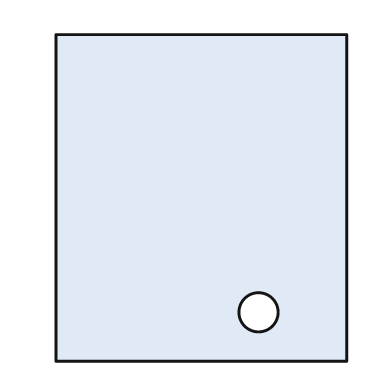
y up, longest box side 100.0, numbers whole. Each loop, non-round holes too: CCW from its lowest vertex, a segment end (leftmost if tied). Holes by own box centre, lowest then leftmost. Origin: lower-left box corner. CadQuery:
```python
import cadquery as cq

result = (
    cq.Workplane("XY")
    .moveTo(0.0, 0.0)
    .lineTo(89.0, 0.0)
    .lineTo(89.0, 100.0)
    .lineTo(0.0, 100.0)
    .close()
    .moveTo(62.0, 15.0)
    .circle(6.0)
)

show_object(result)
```